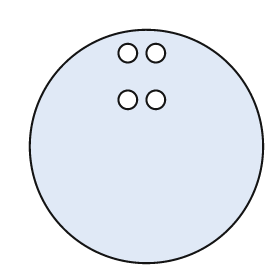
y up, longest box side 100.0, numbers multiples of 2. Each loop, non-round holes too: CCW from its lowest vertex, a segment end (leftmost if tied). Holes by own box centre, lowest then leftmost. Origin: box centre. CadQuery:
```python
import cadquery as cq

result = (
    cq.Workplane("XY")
    .moveTo(0.0, 0.0)
    .circle(50.0)
    .moveTo(-8.0, 20.0)
    .circle(4.0)
    .moveTo(4.0, 20.0)
    .circle(4.0)
    .moveTo(-8.0, 40.0)
    .circle(4.0)
    .moveTo(4.0, 40.0)
    .circle(4.0)
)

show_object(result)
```